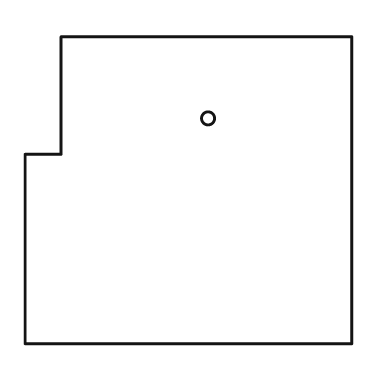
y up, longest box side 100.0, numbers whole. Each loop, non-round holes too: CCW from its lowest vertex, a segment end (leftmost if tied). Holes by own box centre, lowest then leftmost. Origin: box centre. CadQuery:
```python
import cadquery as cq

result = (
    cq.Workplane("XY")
    .moveTo(-50.0, -47.0)
    .lineTo(50.0, -47.0)
    .lineTo(50.0, 47.0)
    .lineTo(-39.0, 47.0)
    .lineTo(-39.0, 11.0)
    .lineTo(-50.0, 11.0)
    .close()
    .moveTo(6.0, 22.0)
    .circle(2.0)
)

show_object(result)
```